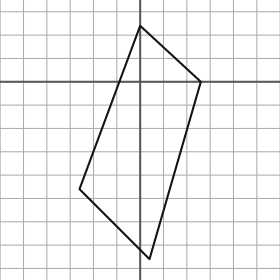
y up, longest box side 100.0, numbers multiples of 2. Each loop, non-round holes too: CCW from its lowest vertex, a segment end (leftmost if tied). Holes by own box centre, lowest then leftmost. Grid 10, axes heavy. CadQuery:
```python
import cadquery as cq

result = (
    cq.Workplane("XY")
    .moveTo(4.0, -76.0)
    .lineTo(26.0, 0.0)
    .lineTo(0.0, 24.0)
    .lineTo(-26.0, -46.0)
    .close()
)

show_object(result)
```